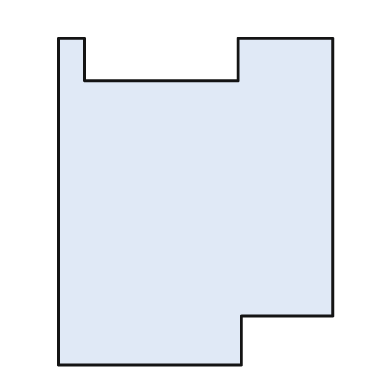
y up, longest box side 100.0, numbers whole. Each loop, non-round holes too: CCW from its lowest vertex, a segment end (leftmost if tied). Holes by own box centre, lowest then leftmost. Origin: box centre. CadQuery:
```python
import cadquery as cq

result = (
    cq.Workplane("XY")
    .moveTo(-42.0, -50.0)
    .lineTo(14.0, -50.0)
    .lineTo(14.0, -35.0)
    .lineTo(42.0, -35.0)
    .lineTo(42.0, 50.0)
    .lineTo(13.0, 50.0)
    .lineTo(13.0, 37.0)
    .lineTo(-34.0, 37.0)
    .lineTo(-34.0, 50.0)
    .lineTo(-42.0, 50.0)
    .close()
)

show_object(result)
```